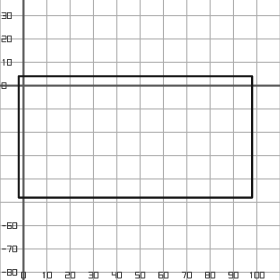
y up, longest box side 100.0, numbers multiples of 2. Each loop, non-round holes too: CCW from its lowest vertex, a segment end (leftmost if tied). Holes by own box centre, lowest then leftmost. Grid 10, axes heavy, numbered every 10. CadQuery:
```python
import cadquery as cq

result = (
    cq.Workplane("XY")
    .moveTo(-2.0, -48.0)
    .lineTo(98.0, -48.0)
    .lineTo(98.0, 4.0)
    .lineTo(-2.0, 4.0)
    .close()
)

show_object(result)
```